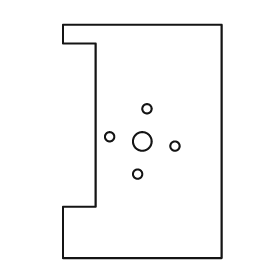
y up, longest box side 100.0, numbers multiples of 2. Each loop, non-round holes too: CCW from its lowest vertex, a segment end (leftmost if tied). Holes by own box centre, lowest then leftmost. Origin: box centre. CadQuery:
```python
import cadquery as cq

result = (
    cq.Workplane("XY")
    .moveTo(-34.0, -50.0)
    .lineTo(34.0, -50.0)
    .lineTo(34.0, 50.0)
    .lineTo(-34.0, 50.0)
    .lineTo(-34.0, 42.0)
    .lineTo(-20.0, 42.0)
    .lineTo(-20.0, -28.0)
    .lineTo(-34.0, -28.0)
    .close()
    .moveTo(-2.0, -14.0)
    .circle(2.0)
    .moveTo(14.0, -2.0)
    .circle(2.0)
    .moveTo(0.0, 0.0)
    .circle(4.0)
    .moveTo(-14.0, 2.0)
    .circle(2.0)
    .moveTo(2.0, 14.0)
    .circle(2.0)
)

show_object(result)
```